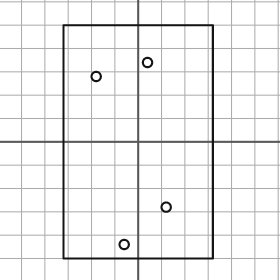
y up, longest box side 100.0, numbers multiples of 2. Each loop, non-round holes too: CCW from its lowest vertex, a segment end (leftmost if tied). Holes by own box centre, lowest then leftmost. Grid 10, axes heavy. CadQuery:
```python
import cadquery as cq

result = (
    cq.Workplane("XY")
    .moveTo(-32.0, -50.0)
    .lineTo(32.0, -50.0)
    .lineTo(32.0, 50.0)
    .lineTo(-32.0, 50.0)
    .close()
    .moveTo(-6.0, -44.0)
    .circle(2.0)
    .moveTo(12.0, -28.0)
    .circle(2.0)
    .moveTo(-18.0, 28.0)
    .circle(2.0)
    .moveTo(4.0, 34.0)
    .circle(2.0)
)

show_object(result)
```